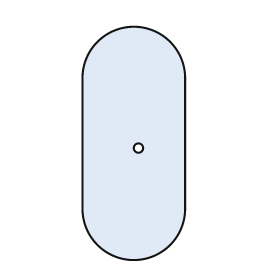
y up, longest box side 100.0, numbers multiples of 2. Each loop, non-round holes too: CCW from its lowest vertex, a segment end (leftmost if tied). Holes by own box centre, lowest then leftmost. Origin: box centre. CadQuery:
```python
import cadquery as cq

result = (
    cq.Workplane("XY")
    .moveTo(-22.0, -28.0)
    .threePointArc((0.0, -50.0), (22.0, -28.0))
    .lineTo(22.0, 28.0)
    .threePointArc((0.0, 50.0), (-22.0, 28.0))
    .close()
    .moveTo(2.0, -2.0)
    .circle(2.0)
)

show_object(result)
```